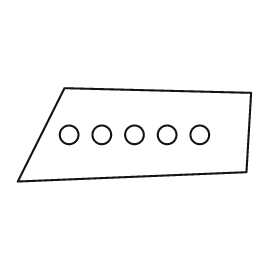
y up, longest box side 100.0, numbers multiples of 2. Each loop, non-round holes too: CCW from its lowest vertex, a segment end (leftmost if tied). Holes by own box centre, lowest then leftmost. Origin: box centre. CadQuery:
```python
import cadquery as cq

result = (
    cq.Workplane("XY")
    .moveTo(-50.0, -20.0)
    .lineTo(48.0, -16.0)
    .lineTo(50.0, 18.0)
    .lineTo(-30.0, 20.0)
    .close()
    .moveTo(-28.0, 0.0)
    .circle(4.0)
    .moveTo(-14.0, 0.0)
    .circle(4.0)
    .moveTo(0.0, 0.0)
    .circle(4.0)
    .moveTo(14.0, 0.0)
    .circle(4.0)
    .moveTo(28.0, 0.0)
    .circle(4.0)
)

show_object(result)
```